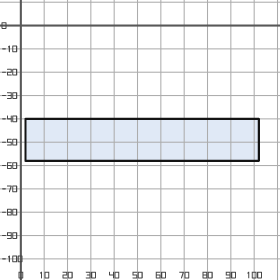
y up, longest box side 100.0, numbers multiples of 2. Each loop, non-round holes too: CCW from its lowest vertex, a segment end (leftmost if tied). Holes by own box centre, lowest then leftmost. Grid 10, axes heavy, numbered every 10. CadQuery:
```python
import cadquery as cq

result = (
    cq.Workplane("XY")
    .moveTo(2.0, -58.0)
    .lineTo(102.0, -58.0)
    .lineTo(102.0, -40.0)
    .lineTo(2.0, -40.0)
    .close()
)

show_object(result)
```